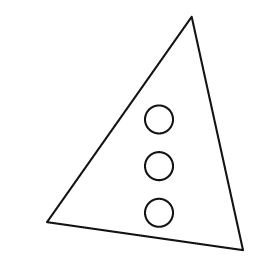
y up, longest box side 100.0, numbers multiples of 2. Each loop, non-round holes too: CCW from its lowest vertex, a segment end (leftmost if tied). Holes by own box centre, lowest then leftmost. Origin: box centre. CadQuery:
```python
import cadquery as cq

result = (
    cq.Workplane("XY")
    .moveTo(42.0, -50.0)
    .lineTo(20.0, 50.0)
    .lineTo(-42.0, -38.0)
    .close()
    .moveTo(6.0, -34.0)
    .circle(6.0)
    .moveTo(6.0, -14.0)
    .circle(6.0)
    .moveTo(6.0, 6.0)
    .circle(6.0)
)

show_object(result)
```